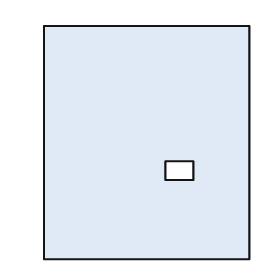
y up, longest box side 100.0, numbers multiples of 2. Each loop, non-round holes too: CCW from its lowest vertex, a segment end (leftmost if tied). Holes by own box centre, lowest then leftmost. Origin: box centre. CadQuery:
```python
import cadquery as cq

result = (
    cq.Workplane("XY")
    .moveTo(-44.0, -50.0)
    .lineTo(44.0, -50.0)
    .lineTo(44.0, 50.0)
    .lineTo(-44.0, 50.0)
    .close()
    .moveTo(8.0, -16.0)
    .lineTo(20.0, -16.0)
    .lineTo(20.0, -8.0)
    .lineTo(8.0, -8.0)
    .close()
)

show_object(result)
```